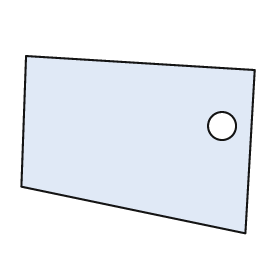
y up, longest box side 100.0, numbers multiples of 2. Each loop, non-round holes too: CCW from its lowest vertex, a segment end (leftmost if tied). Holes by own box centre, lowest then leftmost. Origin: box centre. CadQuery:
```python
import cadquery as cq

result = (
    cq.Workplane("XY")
    .moveTo(46.0, -38.0)
    .lineTo(50.0, 32.0)
    .lineTo(-48.0, 38.0)
    .lineTo(-50.0, -18.0)
    .close()
    .moveTo(36.0, 8.0)
    .circle(6.0)
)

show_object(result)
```